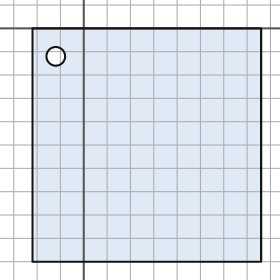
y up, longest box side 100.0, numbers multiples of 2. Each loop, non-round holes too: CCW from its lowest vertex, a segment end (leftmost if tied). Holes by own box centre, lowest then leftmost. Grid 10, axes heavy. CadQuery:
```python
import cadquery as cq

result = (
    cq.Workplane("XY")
    .moveTo(-22.0, -100.0)
    .lineTo(76.0, -100.0)
    .lineTo(76.0, 0.0)
    .lineTo(-22.0, 0.0)
    .close()
    .moveTo(-12.0, -12.0)
    .circle(4.0)
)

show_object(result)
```